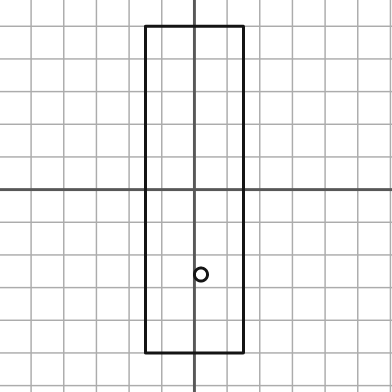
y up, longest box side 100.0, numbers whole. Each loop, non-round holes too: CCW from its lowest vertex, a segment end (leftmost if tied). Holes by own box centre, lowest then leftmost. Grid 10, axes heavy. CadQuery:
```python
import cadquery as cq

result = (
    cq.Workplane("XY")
    .moveTo(-15.0, -50.0)
    .lineTo(15.0, -50.0)
    .lineTo(15.0, 50.0)
    .lineTo(-15.0, 50.0)
    .close()
    .moveTo(2.0, -26.0)
    .circle(2.0)
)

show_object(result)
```